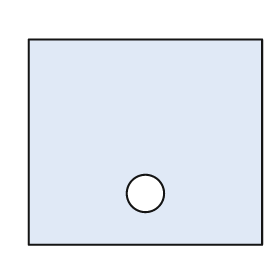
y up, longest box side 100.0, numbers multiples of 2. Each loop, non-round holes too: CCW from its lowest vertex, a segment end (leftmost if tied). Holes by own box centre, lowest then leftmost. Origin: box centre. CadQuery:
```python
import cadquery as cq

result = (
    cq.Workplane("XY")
    .moveTo(-50.0, -44.0)
    .lineTo(50.0, -44.0)
    .lineTo(50.0, 44.0)
    .lineTo(-50.0, 44.0)
    .close()
    .moveTo(0.0, -22.0)
    .circle(8.0)
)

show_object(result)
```